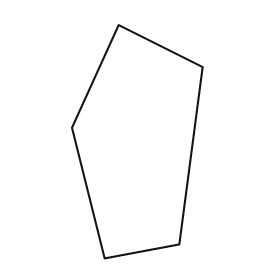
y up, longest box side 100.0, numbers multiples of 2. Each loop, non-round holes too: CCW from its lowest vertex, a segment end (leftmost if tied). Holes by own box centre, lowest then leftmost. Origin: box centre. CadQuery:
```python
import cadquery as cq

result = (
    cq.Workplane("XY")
    .moveTo(-14.0, -50.0)
    .lineTo(18.0, -44.0)
    .lineTo(28.0, 32.0)
    .lineTo(-8.0, 50.0)
    .lineTo(-28.0, 6.0)
    .close()
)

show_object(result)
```